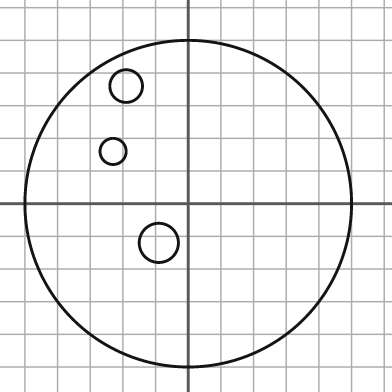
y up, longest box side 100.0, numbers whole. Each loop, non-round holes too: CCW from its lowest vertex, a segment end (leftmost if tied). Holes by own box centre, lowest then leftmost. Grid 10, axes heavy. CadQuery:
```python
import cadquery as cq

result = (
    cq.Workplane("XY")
    .moveTo(0.0, 0.0)
    .circle(50.0)
    .moveTo(-9.0, -12.0)
    .circle(6.0)
    .moveTo(-23.0, 16.0)
    .circle(4.0)
    .moveTo(-19.0, 36.0)
    .circle(5.0)
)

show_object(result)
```